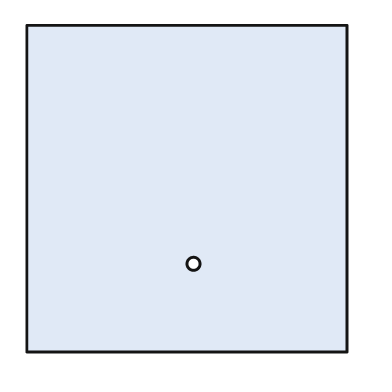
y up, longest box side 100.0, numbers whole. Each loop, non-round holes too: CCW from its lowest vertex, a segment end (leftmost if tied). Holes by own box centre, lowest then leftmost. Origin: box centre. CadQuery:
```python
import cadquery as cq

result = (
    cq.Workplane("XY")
    .moveTo(-49.0, -50.0)
    .lineTo(49.0, -50.0)
    .lineTo(49.0, 50.0)
    .lineTo(-49.0, 50.0)
    .close()
    .moveTo(2.0, -23.0)
    .circle(2.0)
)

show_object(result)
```